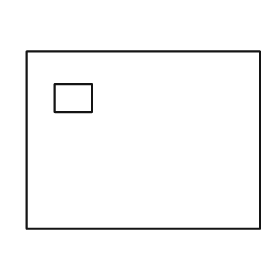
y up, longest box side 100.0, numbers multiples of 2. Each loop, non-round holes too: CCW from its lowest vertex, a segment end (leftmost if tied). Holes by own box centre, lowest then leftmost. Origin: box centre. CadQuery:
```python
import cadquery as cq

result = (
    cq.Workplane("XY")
    .moveTo(-50.0, -38.0)
    .lineTo(50.0, -38.0)
    .lineTo(50.0, 38.0)
    .lineTo(-50.0, 38.0)
    .close()
    .moveTo(-38.0, 12.0)
    .lineTo(-22.0, 12.0)
    .lineTo(-22.0, 24.0)
    .lineTo(-38.0, 24.0)
    .close()
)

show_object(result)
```